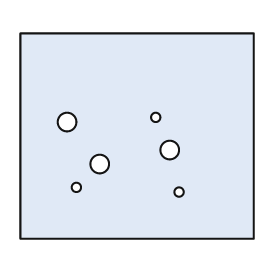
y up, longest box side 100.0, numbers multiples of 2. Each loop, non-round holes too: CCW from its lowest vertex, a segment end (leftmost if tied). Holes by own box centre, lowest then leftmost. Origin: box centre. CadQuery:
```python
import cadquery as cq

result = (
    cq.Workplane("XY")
    .moveTo(-50.0, -44.0)
    .lineTo(50.0, -44.0)
    .lineTo(50.0, 44.0)
    .lineTo(-50.0, 44.0)
    .close()
    .moveTo(18.0, -24.0)
    .circle(2.0)
    .moveTo(-26.0, -22.0)
    .circle(2.0)
    .moveTo(-16.0, -12.0)
    .circle(4.0)
    .moveTo(14.0, -6.0)
    .circle(4.0)
    .moveTo(-30.0, 6.0)
    .circle(4.0)
    .moveTo(8.0, 8.0)
    .circle(2.0)
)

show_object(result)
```